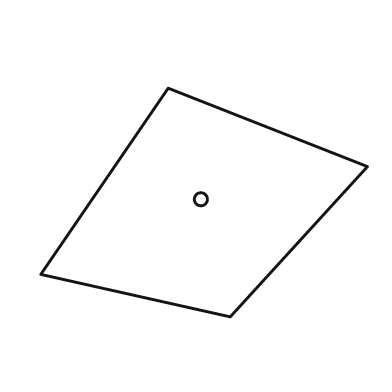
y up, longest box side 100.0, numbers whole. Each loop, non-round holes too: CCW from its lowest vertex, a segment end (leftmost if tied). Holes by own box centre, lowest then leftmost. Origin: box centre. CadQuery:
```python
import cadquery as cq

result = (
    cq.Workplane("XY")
    .moveTo(8.0, -35.0)
    .lineTo(50.0, 11.0)
    .lineTo(-11.0, 35.0)
    .lineTo(-50.0, -22.0)
    .close()
    .moveTo(-1.0, 1.0)
    .circle(2.0)
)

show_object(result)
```